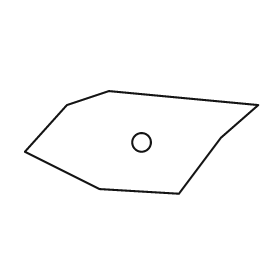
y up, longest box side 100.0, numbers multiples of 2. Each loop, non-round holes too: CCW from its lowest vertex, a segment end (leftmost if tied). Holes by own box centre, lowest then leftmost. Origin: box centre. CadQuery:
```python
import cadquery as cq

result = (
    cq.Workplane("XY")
    .moveTo(16.0, -22.0)
    .lineTo(34.0, 2.0)
    .lineTo(50.0, 16.0)
    .lineTo(-14.0, 22.0)
    .lineTo(-32.0, 16.0)
    .lineTo(-50.0, -4.0)
    .lineTo(-18.0, -20.0)
    .close()
    .moveTo(0.0, 0.0)
    .circle(4.0)
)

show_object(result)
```